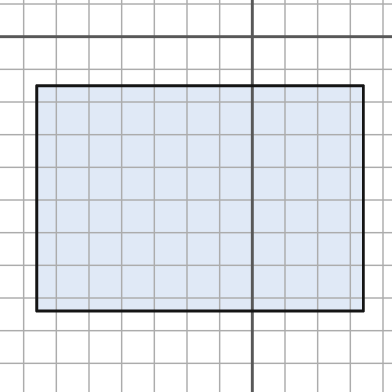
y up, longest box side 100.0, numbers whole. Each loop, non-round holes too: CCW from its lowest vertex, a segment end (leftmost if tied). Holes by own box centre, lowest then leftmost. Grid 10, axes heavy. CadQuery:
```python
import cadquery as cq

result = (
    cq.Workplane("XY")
    .moveTo(-66.0, -84.0)
    .lineTo(34.0, -84.0)
    .lineTo(34.0, -15.0)
    .lineTo(-66.0, -15.0)
    .close()
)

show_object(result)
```